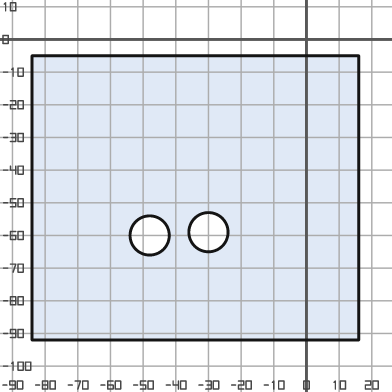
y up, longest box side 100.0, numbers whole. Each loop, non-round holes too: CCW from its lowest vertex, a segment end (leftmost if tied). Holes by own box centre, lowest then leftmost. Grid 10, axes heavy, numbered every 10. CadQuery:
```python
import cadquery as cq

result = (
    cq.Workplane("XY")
    .moveTo(-84.0, -92.0)
    .lineTo(16.0, -92.0)
    .lineTo(16.0, -5.0)
    .lineTo(-84.0, -5.0)
    .close()
    .moveTo(-48.0, -60.0)
    .circle(6.0)
    .moveTo(-30.0, -59.0)
    .circle(6.0)
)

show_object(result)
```